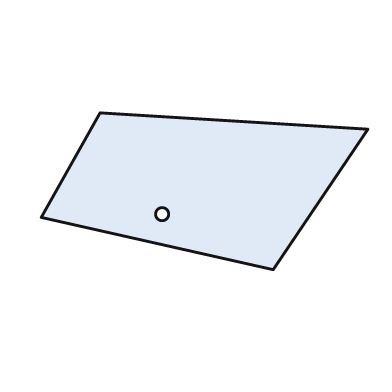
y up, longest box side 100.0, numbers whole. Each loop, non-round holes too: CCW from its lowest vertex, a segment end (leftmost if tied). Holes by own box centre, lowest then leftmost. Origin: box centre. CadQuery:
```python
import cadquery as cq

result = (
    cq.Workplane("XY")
    .moveTo(21.0, -24.0)
    .lineTo(50.0, 19.0)
    .lineTo(-32.0, 24.0)
    .lineTo(-50.0, -8.0)
    .close()
    .moveTo(-13.0, -7.0)
    .circle(2.0)
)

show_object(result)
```